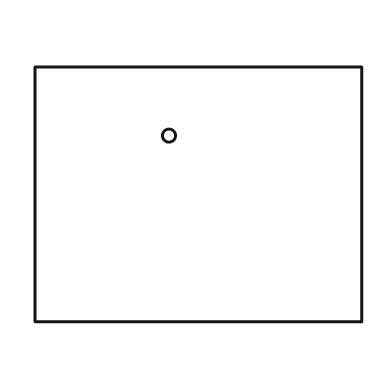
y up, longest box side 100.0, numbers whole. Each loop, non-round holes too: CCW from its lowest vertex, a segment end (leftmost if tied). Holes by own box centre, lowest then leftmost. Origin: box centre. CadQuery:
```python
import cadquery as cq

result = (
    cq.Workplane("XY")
    .moveTo(-50.0, -39.0)
    .lineTo(50.0, -39.0)
    .lineTo(50.0, 39.0)
    .lineTo(-50.0, 39.0)
    .close()
    .moveTo(-9.0, 18.0)
    .circle(2.0)
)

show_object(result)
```